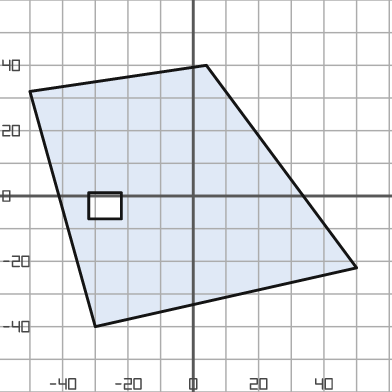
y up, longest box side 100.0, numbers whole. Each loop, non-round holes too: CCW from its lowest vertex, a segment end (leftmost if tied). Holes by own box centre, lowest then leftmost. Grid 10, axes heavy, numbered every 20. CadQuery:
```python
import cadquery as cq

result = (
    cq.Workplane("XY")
    .moveTo(-30.0, -40.0)
    .lineTo(50.0, -22.0)
    .lineTo(4.0, 40.0)
    .lineTo(-50.0, 32.0)
    .close()
    .moveTo(-32.0, -7.0)
    .lineTo(-22.0, -7.0)
    .lineTo(-22.0, 1.0)
    .lineTo(-32.0, 1.0)
    .close()
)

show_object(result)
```